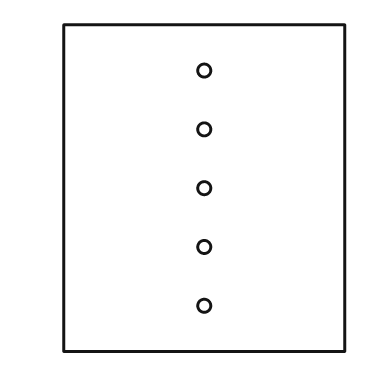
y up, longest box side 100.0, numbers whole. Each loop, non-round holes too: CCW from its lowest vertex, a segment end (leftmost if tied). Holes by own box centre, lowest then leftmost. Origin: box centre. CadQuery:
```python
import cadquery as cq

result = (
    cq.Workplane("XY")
    .moveTo(-43.0, -50.0)
    .lineTo(43.0, -50.0)
    .lineTo(43.0, 50.0)
    .lineTo(-43.0, 50.0)
    .close()
    .moveTo(0.0, -36.0)
    .circle(2.0)
    .moveTo(0.0, -18.0)
    .circle(2.0)
    .moveTo(0.0, 0.0)
    .circle(2.0)
    .moveTo(0.0, 18.0)
    .circle(2.0)
    .moveTo(0.0, 36.0)
    .circle(2.0)
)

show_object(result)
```